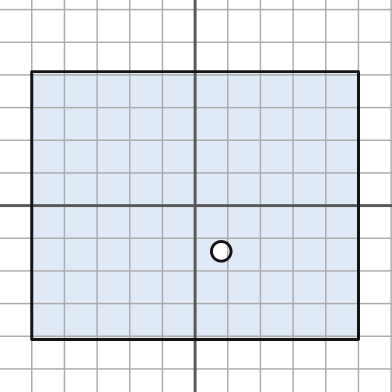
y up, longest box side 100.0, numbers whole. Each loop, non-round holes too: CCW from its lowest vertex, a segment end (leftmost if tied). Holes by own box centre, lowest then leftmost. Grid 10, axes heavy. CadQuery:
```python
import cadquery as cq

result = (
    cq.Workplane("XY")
    .moveTo(-50.0, -41.0)
    .lineTo(50.0, -41.0)
    .lineTo(50.0, 41.0)
    .lineTo(-50.0, 41.0)
    .close()
    .moveTo(8.0, -14.0)
    .circle(3.0)
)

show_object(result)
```